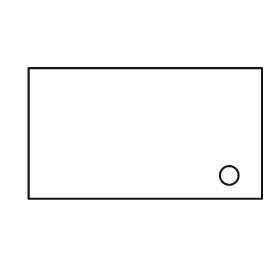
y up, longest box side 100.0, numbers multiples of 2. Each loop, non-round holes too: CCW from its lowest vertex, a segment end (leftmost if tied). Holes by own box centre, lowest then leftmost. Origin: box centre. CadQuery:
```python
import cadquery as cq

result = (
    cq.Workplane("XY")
    .moveTo(-50.0, -28.0)
    .lineTo(50.0, -28.0)
    .lineTo(50.0, 28.0)
    .lineTo(-50.0, 28.0)
    .close()
    .moveTo(36.0, -18.0)
    .circle(4.0)
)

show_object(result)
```